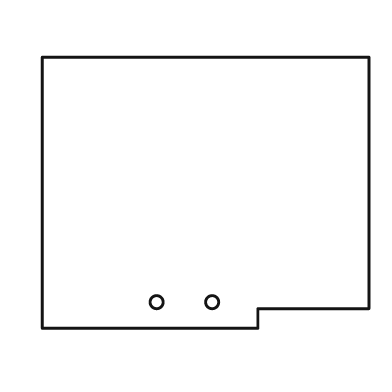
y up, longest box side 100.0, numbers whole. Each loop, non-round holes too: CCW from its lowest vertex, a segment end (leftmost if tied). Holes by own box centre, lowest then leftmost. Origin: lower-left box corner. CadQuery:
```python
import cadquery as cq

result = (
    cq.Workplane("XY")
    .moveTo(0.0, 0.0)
    .lineTo(66.0, 0.0)
    .lineTo(66.0, 6.0)
    .lineTo(100.0, 6.0)
    .lineTo(100.0, 83.0)
    .lineTo(0.0, 83.0)
    .close()
    .moveTo(35.0, 8.0)
    .circle(2.0)
    .moveTo(52.0, 8.0)
    .circle(2.0)
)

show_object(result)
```